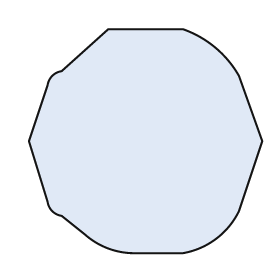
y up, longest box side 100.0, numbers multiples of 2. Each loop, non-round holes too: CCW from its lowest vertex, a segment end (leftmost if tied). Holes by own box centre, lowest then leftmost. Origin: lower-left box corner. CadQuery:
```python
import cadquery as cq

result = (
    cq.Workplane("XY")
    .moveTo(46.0, 0.0)
    .lineTo(66.0, 0.0)
    .threePointArc((80.0, 6.0), (90.0, 18.0))
    .lineTo(100.0, 48.0)
    .lineTo(90.0, 76.0)
    .threePointArc((80.0, 88.0), (66.0, 96.0))
    .lineTo(34.0, 96.0)
    .lineTo(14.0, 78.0)
    .threePointArc((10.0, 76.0), (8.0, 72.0))
    .lineTo(0.0, 48.0)
    .lineTo(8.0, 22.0)
    .threePointArc((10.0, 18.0), (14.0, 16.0))
    .lineTo(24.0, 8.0)
    .threePointArc((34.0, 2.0), (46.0, 0.0))
    .close()
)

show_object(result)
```